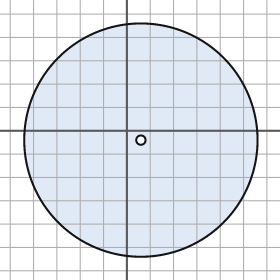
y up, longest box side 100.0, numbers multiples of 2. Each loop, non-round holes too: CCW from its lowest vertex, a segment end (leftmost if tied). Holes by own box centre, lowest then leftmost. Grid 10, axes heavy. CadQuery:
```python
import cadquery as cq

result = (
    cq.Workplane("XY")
    .moveTo(6.0, -4.0)
    .circle(50.0)
    .moveTo(6.0, -4.0)
    .circle(2.0)
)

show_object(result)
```